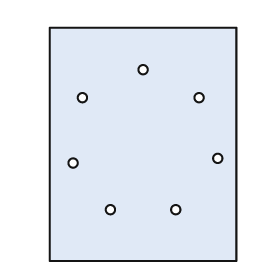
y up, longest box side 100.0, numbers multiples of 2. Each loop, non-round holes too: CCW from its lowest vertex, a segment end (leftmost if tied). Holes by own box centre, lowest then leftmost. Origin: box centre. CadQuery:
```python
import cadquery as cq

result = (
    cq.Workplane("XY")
    .moveTo(-40.0, -50.0)
    .lineTo(40.0, -50.0)
    .lineTo(40.0, 50.0)
    .lineTo(-40.0, 50.0)
    .close()
    .moveTo(-14.0, -28.0)
    .circle(2.0)
    .moveTo(14.0, -28.0)
    .circle(2.0)
    .moveTo(-30.0, -8.0)
    .circle(2.0)
    .moveTo(32.0, -6.0)
    .circle(2.0)
    .moveTo(-26.0, 20.0)
    .circle(2.0)
    .moveTo(24.0, 20.0)
    .circle(2.0)
    .moveTo(0.0, 32.0)
    .circle(2.0)
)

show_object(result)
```